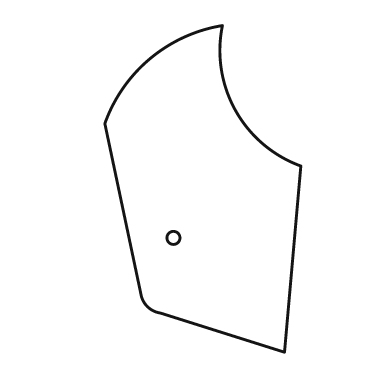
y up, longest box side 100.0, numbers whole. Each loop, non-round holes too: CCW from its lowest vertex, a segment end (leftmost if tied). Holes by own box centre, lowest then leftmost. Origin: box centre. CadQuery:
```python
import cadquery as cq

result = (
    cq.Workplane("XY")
    .moveTo(25.0, -50.0)
    .lineTo(30.0, 7.0)
    .threePointArc((10.0, 24.0), (6.0, 50.0))
    .threePointArc((-16.0, 40.0), (-30.0, 20.0))
    .lineTo(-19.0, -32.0)
    .threePointArc((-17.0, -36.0), (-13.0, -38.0))
    .close()
    .moveTo(-9.0, -15.0)
    .circle(2.0)
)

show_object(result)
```